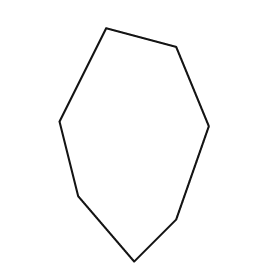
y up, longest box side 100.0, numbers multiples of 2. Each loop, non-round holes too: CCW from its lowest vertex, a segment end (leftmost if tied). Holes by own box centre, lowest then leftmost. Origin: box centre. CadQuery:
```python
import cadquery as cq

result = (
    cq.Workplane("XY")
    .moveTo(0.0, -50.0)
    .lineTo(18.0, -32.0)
    .lineTo(32.0, 8.0)
    .lineTo(18.0, 42.0)
    .lineTo(-12.0, 50.0)
    .lineTo(-32.0, 10.0)
    .lineTo(-24.0, -22.0)
    .close()
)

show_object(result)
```